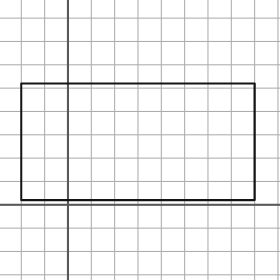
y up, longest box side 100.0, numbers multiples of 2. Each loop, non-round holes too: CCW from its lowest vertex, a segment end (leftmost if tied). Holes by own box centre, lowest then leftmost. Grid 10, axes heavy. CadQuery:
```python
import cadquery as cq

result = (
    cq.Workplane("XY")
    .moveTo(-20.0, 2.0)
    .lineTo(80.0, 2.0)
    .lineTo(80.0, 52.0)
    .lineTo(-20.0, 52.0)
    .close()
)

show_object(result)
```